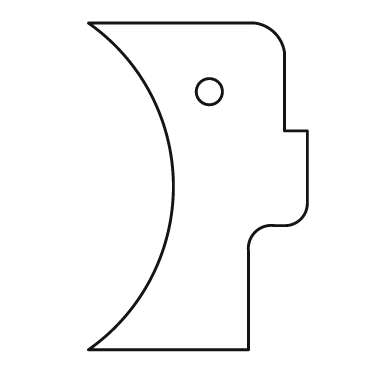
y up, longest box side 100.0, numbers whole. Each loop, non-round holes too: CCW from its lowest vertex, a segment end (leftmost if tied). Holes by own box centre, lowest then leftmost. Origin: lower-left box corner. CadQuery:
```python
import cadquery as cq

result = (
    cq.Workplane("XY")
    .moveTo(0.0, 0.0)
    .lineTo(49.0, 0.0)
    .lineTo(49.0, 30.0)
    .threePointArc((51.0, 36.0), (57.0, 38.0))
    .lineTo(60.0, 38.0)
    .threePointArc((65.0, 40.0), (67.0, 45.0))
    .lineTo(67.0, 67.0)
    .lineTo(60.0, 67.0)
    .lineTo(60.0, 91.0)
    .threePointArc((57.0, 97.0), (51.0, 100.0))
    .lineTo(0.0, 100.0)
    .threePointArc((26.0, 50.0), (0.0, 0.0))
    .close()
    .moveTo(37.0, 79.0)
    .circle(4.0)
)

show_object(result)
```